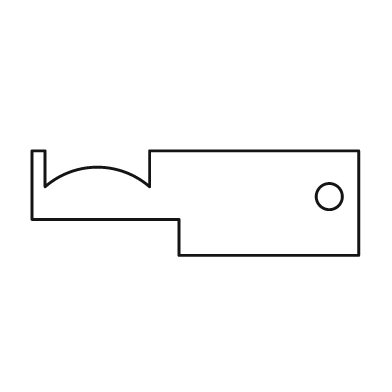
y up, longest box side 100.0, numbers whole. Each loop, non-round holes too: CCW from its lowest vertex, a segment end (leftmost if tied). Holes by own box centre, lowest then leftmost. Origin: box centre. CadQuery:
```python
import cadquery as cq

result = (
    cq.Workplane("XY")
    .moveTo(-5.0, -16.0)
    .lineTo(50.0, -16.0)
    .lineTo(50.0, 16.0)
    .lineTo(-14.0, 16.0)
    .lineTo(-14.0, 5.0)
    .threePointArc((-30.0, 11.0), (-46.0, 5.0))
    .lineTo(-46.0, 16.0)
    .lineTo(-50.0, 16.0)
    .lineTo(-50.0, -5.0)
    .lineTo(-5.0, -5.0)
    .close()
    .moveTo(41.0, 2.0)
    .circle(4.0)
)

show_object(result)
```